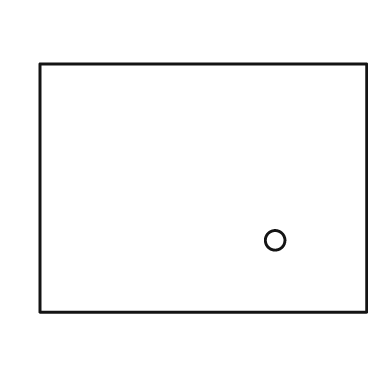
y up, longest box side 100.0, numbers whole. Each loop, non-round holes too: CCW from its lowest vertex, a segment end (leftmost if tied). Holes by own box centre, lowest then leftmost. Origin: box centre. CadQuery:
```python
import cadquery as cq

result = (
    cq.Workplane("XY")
    .moveTo(-50.0, -38.0)
    .lineTo(50.0, -38.0)
    .lineTo(50.0, 38.0)
    .lineTo(-50.0, 38.0)
    .close()
    .moveTo(22.0, -16.0)
    .circle(3.0)
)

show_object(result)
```